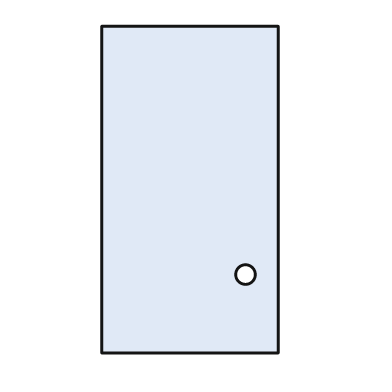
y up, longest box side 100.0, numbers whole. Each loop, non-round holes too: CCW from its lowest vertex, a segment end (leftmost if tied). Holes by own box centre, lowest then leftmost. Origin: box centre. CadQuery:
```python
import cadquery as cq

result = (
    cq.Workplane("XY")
    .moveTo(-27.0, -50.0)
    .lineTo(27.0, -50.0)
    .lineTo(27.0, 50.0)
    .lineTo(-27.0, 50.0)
    .close()
    .moveTo(17.0, -26.0)
    .circle(3.0)
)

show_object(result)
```